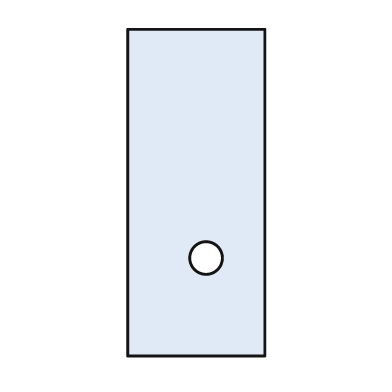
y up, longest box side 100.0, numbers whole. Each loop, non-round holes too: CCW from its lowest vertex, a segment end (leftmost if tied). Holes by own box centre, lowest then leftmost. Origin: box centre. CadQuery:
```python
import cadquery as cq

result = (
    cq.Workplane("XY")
    .moveTo(-21.0, -50.0)
    .lineTo(21.0, -50.0)
    .lineTo(21.0, 50.0)
    .lineTo(-21.0, 50.0)
    .close()
    .moveTo(3.0, -20.0)
    .circle(5.0)
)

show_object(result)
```